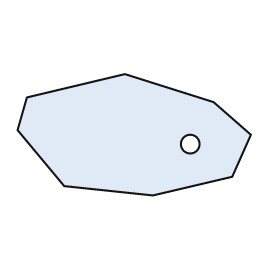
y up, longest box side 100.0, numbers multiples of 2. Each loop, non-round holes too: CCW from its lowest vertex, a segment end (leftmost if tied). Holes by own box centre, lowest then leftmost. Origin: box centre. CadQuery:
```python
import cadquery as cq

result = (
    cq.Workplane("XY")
    .moveTo(8.0, -26.0)
    .lineTo(42.0, -18.0)
    .lineTo(50.0, 0.0)
    .lineTo(34.0, 14.0)
    .lineTo(-4.0, 26.0)
    .lineTo(-46.0, 16.0)
    .lineTo(-50.0, 2.0)
    .lineTo(-30.0, -22.0)
    .close()
    .moveTo(24.0, -4.0)
    .circle(4.0)
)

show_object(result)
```